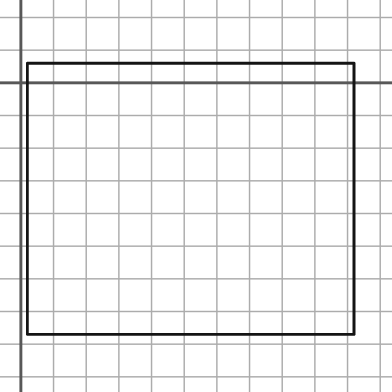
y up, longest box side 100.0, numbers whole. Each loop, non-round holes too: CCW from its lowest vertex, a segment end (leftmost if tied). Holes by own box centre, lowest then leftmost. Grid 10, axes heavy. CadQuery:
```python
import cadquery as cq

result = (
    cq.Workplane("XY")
    .moveTo(2.0, -77.0)
    .lineTo(102.0, -77.0)
    .lineTo(102.0, 6.0)
    .lineTo(2.0, 6.0)
    .close()
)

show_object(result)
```